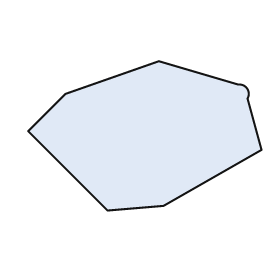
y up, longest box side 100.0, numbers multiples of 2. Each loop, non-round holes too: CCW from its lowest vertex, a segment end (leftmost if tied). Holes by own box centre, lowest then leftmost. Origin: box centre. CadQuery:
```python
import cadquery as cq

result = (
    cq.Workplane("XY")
    .moveTo(-16.0, -32.0)
    .lineTo(8.0, -30.0)
    .lineTo(50.0, -6.0)
    .lineTo(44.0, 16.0)
    .threePointArc((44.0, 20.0), (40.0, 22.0))
    .lineTo(6.0, 32.0)
    .lineTo(-34.0, 18.0)
    .lineTo(-50.0, 2.0)
    .close()
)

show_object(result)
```